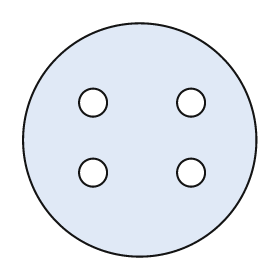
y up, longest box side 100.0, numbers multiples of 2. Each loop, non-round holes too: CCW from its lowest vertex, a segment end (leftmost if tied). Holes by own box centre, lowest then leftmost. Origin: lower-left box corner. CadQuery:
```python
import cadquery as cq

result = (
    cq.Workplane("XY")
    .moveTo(50.0, 50.0)
    .circle(50.0)
    .moveTo(30.0, 36.0)
    .circle(6.0)
    .moveTo(72.0, 36.0)
    .circle(6.0)
    .moveTo(30.0, 66.0)
    .circle(6.0)
    .moveTo(72.0, 66.0)
    .circle(6.0)
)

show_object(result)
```